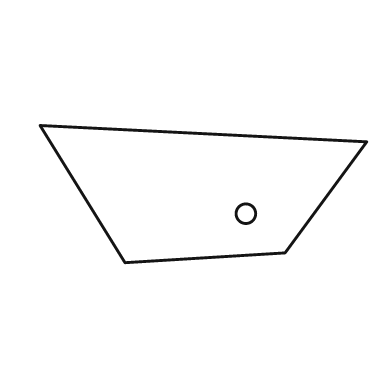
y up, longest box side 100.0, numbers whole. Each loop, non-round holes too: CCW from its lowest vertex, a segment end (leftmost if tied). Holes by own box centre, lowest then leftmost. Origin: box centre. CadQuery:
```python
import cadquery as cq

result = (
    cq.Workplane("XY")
    .moveTo(-24.0, -21.0)
    .lineTo(25.0, -18.0)
    .lineTo(50.0, 16.0)
    .lineTo(-50.0, 21.0)
    .close()
    .moveTo(13.0, -6.0)
    .circle(3.0)
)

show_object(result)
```